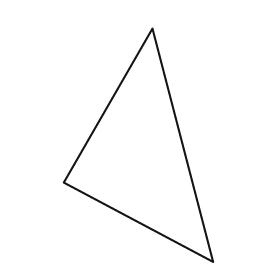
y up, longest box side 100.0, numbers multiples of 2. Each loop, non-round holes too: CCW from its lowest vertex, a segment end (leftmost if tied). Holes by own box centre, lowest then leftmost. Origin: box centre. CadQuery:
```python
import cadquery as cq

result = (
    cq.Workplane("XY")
    .moveTo(32.0, -50.0)
    .lineTo(6.0, 50.0)
    .lineTo(-32.0, -16.0)
    .close()
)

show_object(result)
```